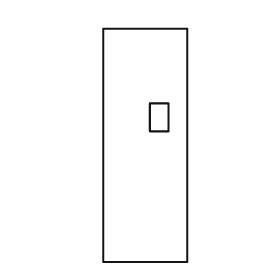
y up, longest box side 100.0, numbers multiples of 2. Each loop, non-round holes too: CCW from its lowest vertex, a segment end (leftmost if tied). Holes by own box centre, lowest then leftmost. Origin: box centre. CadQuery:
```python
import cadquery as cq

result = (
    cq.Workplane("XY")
    .moveTo(-18.0, -50.0)
    .lineTo(18.0, -50.0)
    .lineTo(18.0, 50.0)
    .lineTo(-18.0, 50.0)
    .close()
    .moveTo(2.0, 6.0)
    .lineTo(10.0, 6.0)
    .lineTo(10.0, 18.0)
    .lineTo(2.0, 18.0)
    .close()
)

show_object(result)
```